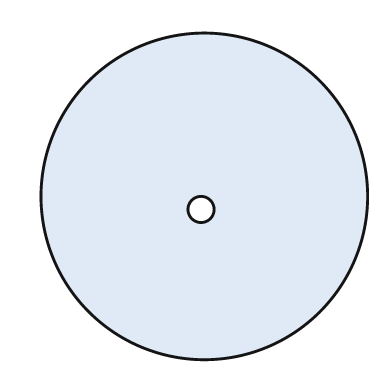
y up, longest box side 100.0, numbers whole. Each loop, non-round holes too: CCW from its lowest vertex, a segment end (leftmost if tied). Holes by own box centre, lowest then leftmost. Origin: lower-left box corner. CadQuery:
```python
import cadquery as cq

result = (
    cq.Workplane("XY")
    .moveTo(50.0, 50.0)
    .circle(50.0)
    .moveTo(49.0, 46.0)
    .circle(4.0)
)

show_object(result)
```